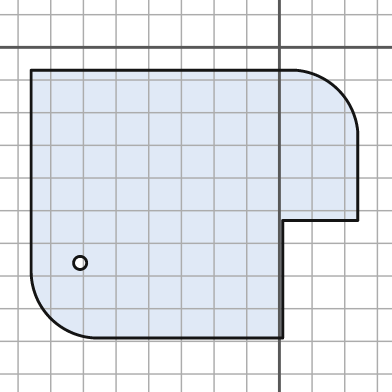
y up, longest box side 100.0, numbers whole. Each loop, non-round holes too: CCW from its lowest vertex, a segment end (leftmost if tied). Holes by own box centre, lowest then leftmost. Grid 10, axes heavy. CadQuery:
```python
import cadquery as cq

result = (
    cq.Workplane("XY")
    .moveTo(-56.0, -89.0)
    .lineTo(1.0, -89.0)
    .lineTo(1.0, -53.0)
    .lineTo(24.0, -53.0)
    .lineTo(24.0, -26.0)
    .threePointArc((18.0, -13.0), (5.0, -7.0))
    .lineTo(-76.0, -7.0)
    .lineTo(-76.0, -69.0)
    .threePointArc((-70.0, -83.0), (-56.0, -89.0))
    .close()
    .moveTo(-61.0, -66.0)
    .circle(2.0)
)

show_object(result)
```